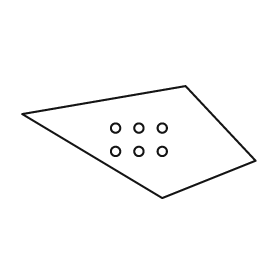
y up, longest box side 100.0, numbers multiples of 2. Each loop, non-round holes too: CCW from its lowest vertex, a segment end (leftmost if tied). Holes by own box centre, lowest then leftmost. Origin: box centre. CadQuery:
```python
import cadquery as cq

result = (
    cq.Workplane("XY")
    .moveTo(10.0, -24.0)
    .lineTo(50.0, -8.0)
    .lineTo(20.0, 24.0)
    .lineTo(-50.0, 12.0)
    .close()
    .moveTo(-10.0, -4.0)
    .circle(2.0)
    .moveTo(0.0, -4.0)
    .circle(2.0)
    .moveTo(10.0, -4.0)
    .circle(2.0)
    .moveTo(-10.0, 6.0)
    .circle(2.0)
    .moveTo(0.0, 6.0)
    .circle(2.0)
    .moveTo(10.0, 6.0)
    .circle(2.0)
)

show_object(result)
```